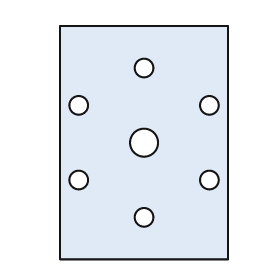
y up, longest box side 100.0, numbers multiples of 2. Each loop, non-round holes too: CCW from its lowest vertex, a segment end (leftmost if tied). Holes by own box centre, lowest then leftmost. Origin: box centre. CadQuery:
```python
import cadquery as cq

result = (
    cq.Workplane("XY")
    .moveTo(-36.0, -50.0)
    .lineTo(36.0, -50.0)
    .lineTo(36.0, 50.0)
    .lineTo(-36.0, 50.0)
    .close()
    .moveTo(0.0, -32.0)
    .circle(4.0)
    .moveTo(-28.0, -16.0)
    .circle(4.0)
    .moveTo(28.0, -16.0)
    .circle(4.0)
    .moveTo(0.0, 0.0)
    .circle(6.0)
    .moveTo(-28.0, 16.0)
    .circle(4.0)
    .moveTo(28.0, 16.0)
    .circle(4.0)
    .moveTo(0.0, 32.0)
    .circle(4.0)
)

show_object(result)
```